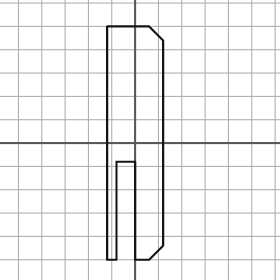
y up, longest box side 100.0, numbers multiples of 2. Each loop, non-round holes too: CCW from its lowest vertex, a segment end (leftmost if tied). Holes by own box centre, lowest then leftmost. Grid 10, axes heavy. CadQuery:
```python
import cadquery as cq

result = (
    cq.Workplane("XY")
    .moveTo(-12.0, -50.0)
    .lineTo(-8.0, -50.0)
    .lineTo(-8.0, -8.0)
    .lineTo(0.0, -8.0)
    .lineTo(0.0, -50.0)
    .lineTo(6.0, -50.0)
    .lineTo(12.0, -44.0)
    .lineTo(12.0, 44.0)
    .lineTo(6.0, 50.0)
    .lineTo(-12.0, 50.0)
    .close()
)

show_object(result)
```